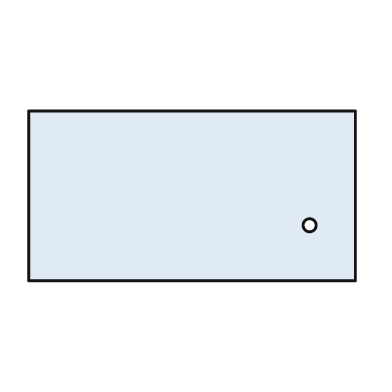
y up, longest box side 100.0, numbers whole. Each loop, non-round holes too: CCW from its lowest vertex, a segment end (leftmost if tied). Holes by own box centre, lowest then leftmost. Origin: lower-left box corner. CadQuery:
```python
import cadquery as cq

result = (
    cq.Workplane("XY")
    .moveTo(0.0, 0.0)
    .lineTo(100.0, 0.0)
    .lineTo(100.0, 52.0)
    .lineTo(0.0, 52.0)
    .close()
    .moveTo(86.0, 17.0)
    .circle(2.0)
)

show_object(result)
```